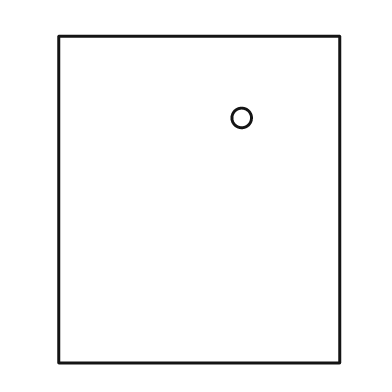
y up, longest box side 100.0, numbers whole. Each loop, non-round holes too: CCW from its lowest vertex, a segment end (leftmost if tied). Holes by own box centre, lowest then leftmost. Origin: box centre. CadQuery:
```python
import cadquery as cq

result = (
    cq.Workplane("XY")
    .moveTo(-43.0, -50.0)
    .lineTo(43.0, -50.0)
    .lineTo(43.0, 50.0)
    .lineTo(-43.0, 50.0)
    .close()
    .moveTo(13.0, 25.0)
    .circle(3.0)
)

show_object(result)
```